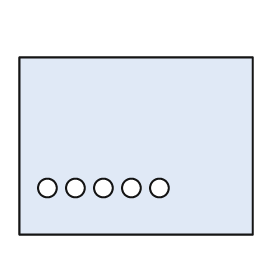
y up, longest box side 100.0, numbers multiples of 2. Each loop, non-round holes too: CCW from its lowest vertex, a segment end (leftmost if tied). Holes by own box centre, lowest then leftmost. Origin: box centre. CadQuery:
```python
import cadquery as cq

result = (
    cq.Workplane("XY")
    .moveTo(-50.0, -38.0)
    .lineTo(50.0, -38.0)
    .lineTo(50.0, 38.0)
    .lineTo(-50.0, 38.0)
    .close()
    .moveTo(-38.0, -18.0)
    .circle(4.0)
    .moveTo(-26.0, -18.0)
    .circle(4.0)
    .moveTo(-14.0, -18.0)
    .circle(4.0)
    .moveTo(-2.0, -18.0)
    .circle(4.0)
    .moveTo(10.0, -18.0)
    .circle(4.0)
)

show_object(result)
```